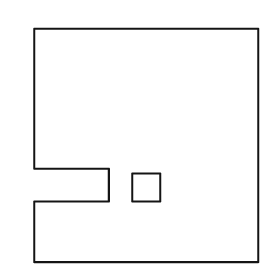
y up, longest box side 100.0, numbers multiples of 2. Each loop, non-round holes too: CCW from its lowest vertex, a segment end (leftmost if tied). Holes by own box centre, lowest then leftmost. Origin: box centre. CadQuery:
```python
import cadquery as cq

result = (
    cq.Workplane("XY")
    .moveTo(-48.0, -50.0)
    .lineTo(48.0, -50.0)
    .lineTo(48.0, 50.0)
    .lineTo(-48.0, 50.0)
    .lineTo(-48.0, -10.0)
    .lineTo(-16.0, -10.0)
    .lineTo(-16.0, -24.0)
    .lineTo(-48.0, -24.0)
    .close()
    .moveTo(-6.0, -24.0)
    .lineTo(6.0, -24.0)
    .lineTo(6.0, -12.0)
    .lineTo(-6.0, -12.0)
    .close()
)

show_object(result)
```